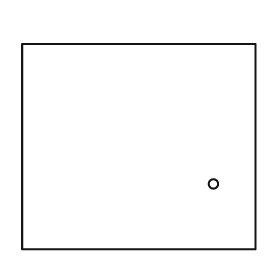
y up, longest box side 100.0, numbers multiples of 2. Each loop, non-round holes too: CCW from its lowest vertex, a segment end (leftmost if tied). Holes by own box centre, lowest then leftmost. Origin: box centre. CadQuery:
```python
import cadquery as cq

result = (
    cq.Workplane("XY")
    .moveTo(-50.0, -44.0)
    .lineTo(50.0, -44.0)
    .lineTo(50.0, 44.0)
    .lineTo(-50.0, 44.0)
    .close()
    .moveTo(32.0, -16.0)
    .circle(2.0)
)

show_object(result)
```